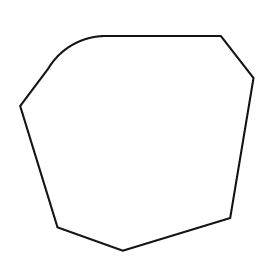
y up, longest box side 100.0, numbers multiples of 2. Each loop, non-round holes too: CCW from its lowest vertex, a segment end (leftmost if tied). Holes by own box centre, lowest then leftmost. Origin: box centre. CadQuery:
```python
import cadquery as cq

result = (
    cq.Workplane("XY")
    .moveTo(-6.0, -46.0)
    .lineTo(40.0, -32.0)
    .lineTo(50.0, 28.0)
    .lineTo(36.0, 46.0)
    .lineTo(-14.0, 46.0)
    .threePointArc((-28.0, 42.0), (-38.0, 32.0))
    .lineTo(-50.0, 16.0)
    .lineTo(-34.0, -36.0)
    .close()
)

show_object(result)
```